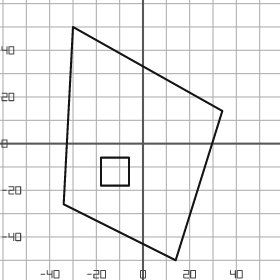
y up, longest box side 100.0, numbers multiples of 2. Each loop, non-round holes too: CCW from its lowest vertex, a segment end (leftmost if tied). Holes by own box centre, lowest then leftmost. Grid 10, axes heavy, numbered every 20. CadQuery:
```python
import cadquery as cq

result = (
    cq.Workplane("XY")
    .moveTo(14.0, -50.0)
    .lineTo(34.0, 14.0)
    .lineTo(-30.0, 50.0)
    .lineTo(-34.0, -26.0)
    .close()
    .moveTo(-18.0, -18.0)
    .lineTo(-6.0, -18.0)
    .lineTo(-6.0, -6.0)
    .lineTo(-18.0, -6.0)
    .close()
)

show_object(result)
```